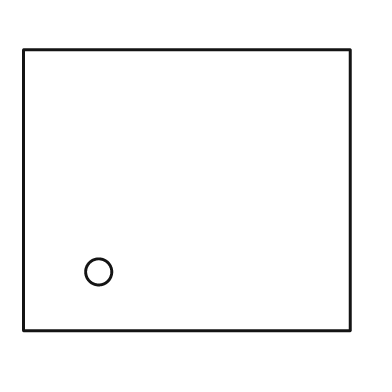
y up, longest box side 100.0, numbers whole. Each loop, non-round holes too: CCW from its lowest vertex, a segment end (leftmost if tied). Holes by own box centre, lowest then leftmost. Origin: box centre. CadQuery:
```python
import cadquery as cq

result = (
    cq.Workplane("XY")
    .moveTo(-50.0, -43.0)
    .lineTo(50.0, -43.0)
    .lineTo(50.0, 43.0)
    .lineTo(-50.0, 43.0)
    .close()
    .moveTo(-27.0, -25.0)
    .circle(4.0)
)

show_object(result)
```